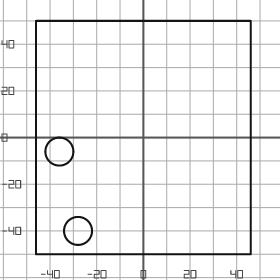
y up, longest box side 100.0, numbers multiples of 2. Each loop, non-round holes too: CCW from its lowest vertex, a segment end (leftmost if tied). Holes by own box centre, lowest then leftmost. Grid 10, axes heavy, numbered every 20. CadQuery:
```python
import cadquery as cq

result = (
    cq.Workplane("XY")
    .moveTo(-46.0, -50.0)
    .lineTo(46.0, -50.0)
    .lineTo(46.0, 50.0)
    .lineTo(-46.0, 50.0)
    .close()
    .moveTo(-28.0, -40.0)
    .circle(6.0)
    .moveTo(-36.0, -6.0)
    .circle(6.0)
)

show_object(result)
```